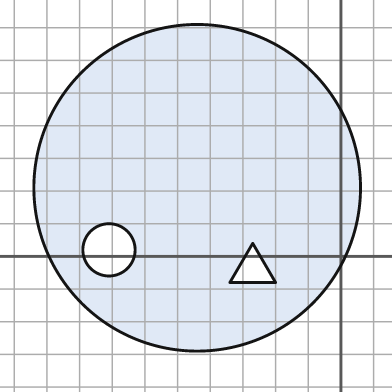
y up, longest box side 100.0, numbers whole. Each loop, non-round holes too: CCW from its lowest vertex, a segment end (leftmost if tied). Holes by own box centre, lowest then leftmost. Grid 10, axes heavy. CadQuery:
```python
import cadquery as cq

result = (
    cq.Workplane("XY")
    .moveTo(-44.0, 21.0)
    .circle(50.0)
    .moveTo(-34.0, -8.0)
    .lineTo(-20.0, -8.0)
    .lineTo(-27.0, 4.0)
    .close()
    .moveTo(-71.0, 2.0)
    .circle(8.0)
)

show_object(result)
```